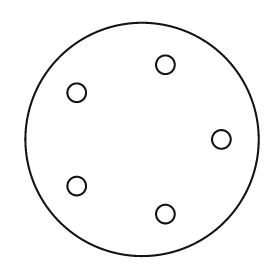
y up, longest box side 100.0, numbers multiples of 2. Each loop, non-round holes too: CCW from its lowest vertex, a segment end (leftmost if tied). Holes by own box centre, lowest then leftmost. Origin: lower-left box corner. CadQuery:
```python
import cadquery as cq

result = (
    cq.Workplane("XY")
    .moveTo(50.0, 50.0)
    .circle(50.0)
    .moveTo(60.0, 18.0)
    .circle(4.0)
    .moveTo(22.0, 30.0)
    .circle(4.0)
    .moveTo(84.0, 50.0)
    .circle(4.0)
    .moveTo(22.0, 70.0)
    .circle(4.0)
    .moveTo(60.0, 82.0)
    .circle(4.0)
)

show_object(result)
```